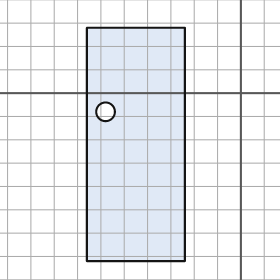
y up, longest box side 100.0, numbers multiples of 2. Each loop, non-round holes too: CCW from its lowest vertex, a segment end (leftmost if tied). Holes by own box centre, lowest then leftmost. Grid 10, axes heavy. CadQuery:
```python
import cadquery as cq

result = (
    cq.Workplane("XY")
    .moveTo(-66.0, -72.0)
    .lineTo(-24.0, -72.0)
    .lineTo(-24.0, 28.0)
    .lineTo(-66.0, 28.0)
    .close()
    .moveTo(-58.0, -8.0)
    .circle(4.0)
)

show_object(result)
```